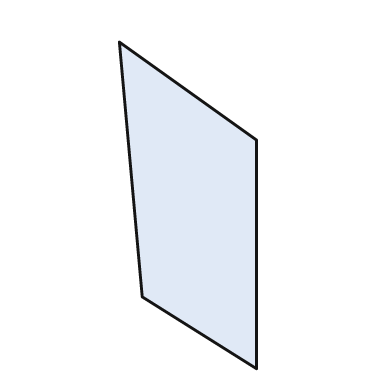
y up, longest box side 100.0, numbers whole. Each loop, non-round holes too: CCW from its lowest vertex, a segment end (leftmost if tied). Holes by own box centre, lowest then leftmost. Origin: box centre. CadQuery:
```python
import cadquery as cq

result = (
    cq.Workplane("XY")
    .moveTo(21.0, -50.0)
    .lineTo(21.0, 20.0)
    .lineTo(-21.0, 50.0)
    .lineTo(-14.0, -28.0)
    .close()
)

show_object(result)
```